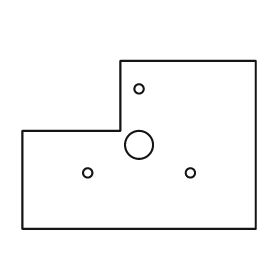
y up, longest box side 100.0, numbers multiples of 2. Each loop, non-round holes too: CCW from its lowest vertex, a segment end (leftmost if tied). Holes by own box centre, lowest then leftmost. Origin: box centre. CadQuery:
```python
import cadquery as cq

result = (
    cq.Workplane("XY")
    .moveTo(-50.0, -36.0)
    .lineTo(50.0, -36.0)
    .lineTo(50.0, 36.0)
    .lineTo(-8.0, 36.0)
    .lineTo(-8.0, 6.0)
    .lineTo(-50.0, 6.0)
    .close()
    .moveTo(-22.0, -12.0)
    .circle(2.0)
    .moveTo(22.0, -12.0)
    .circle(2.0)
    .moveTo(0.0, 0.0)
    .circle(6.0)
    .moveTo(0.0, 24.0)
    .circle(2.0)
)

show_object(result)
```